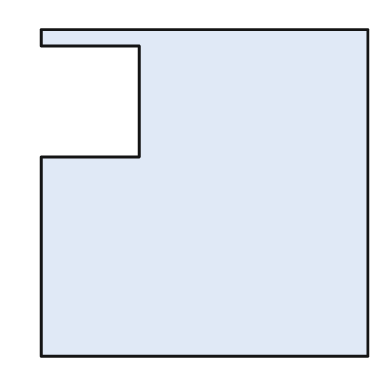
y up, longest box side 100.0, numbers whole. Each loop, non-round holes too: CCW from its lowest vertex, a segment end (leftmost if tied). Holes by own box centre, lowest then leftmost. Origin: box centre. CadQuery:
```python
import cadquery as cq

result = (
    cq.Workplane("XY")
    .moveTo(-50.0, -50.0)
    .lineTo(50.0, -50.0)
    .lineTo(50.0, 50.0)
    .lineTo(-50.0, 50.0)
    .lineTo(-50.0, 45.0)
    .lineTo(-20.0, 45.0)
    .lineTo(-20.0, 11.0)
    .lineTo(-50.0, 11.0)
    .close()
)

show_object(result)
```